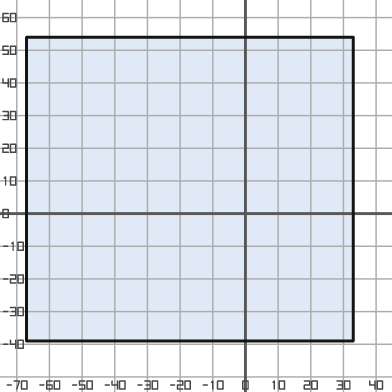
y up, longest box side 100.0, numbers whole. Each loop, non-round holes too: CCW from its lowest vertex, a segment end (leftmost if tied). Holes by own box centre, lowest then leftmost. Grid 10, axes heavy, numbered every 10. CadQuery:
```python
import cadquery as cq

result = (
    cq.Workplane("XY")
    .moveTo(-67.0, -39.0)
    .lineTo(33.0, -39.0)
    .lineTo(33.0, 54.0)
    .lineTo(-67.0, 54.0)
    .close()
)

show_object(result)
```